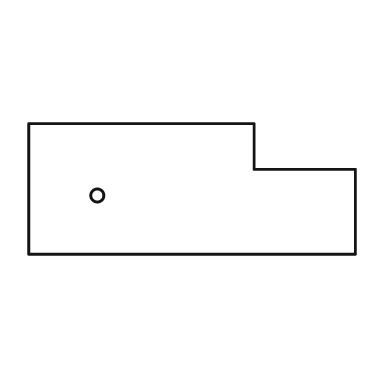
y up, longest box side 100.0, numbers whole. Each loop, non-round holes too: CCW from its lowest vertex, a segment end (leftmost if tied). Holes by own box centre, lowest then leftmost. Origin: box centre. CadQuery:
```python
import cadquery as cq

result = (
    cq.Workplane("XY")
    .moveTo(-50.0, -20.0)
    .lineTo(50.0, -20.0)
    .lineTo(50.0, 6.0)
    .lineTo(19.0, 6.0)
    .lineTo(19.0, 20.0)
    .lineTo(-50.0, 20.0)
    .close()
    .moveTo(-29.0, -2.0)
    .circle(2.0)
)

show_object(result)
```